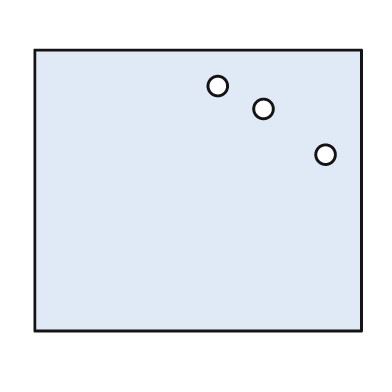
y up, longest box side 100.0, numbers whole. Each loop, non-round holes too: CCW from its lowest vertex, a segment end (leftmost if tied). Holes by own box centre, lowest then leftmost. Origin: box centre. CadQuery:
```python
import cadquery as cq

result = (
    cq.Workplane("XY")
    .moveTo(-50.0, -43.0)
    .lineTo(50.0, -43.0)
    .lineTo(50.0, 43.0)
    .lineTo(-50.0, 43.0)
    .close()
    .moveTo(39.0, 11.0)
    .circle(3.0)
    .moveTo(20.0, 25.0)
    .circle(3.0)
    .moveTo(6.0, 32.0)
    .circle(3.0)
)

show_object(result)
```